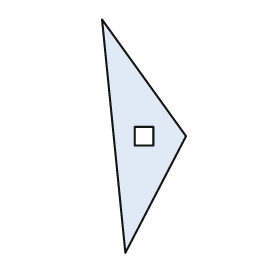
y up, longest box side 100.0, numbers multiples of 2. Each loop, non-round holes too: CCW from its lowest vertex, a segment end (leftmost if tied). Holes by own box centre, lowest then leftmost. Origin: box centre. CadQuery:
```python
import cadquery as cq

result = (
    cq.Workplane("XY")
    .moveTo(-8.0, -50.0)
    .lineTo(18.0, 0.0)
    .lineTo(-18.0, 50.0)
    .close()
    .moveTo(-4.0, -4.0)
    .lineTo(4.0, -4.0)
    .lineTo(4.0, 4.0)
    .lineTo(-4.0, 4.0)
    .close()
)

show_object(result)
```